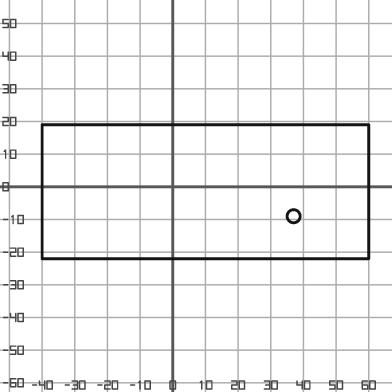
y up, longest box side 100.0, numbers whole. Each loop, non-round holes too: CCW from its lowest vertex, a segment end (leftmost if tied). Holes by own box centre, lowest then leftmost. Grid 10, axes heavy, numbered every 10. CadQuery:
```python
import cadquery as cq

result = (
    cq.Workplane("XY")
    .moveTo(-40.0, -22.0)
    .lineTo(60.0, -22.0)
    .lineTo(60.0, 19.0)
    .lineTo(-40.0, 19.0)
    .close()
    .moveTo(37.0, -9.0)
    .circle(2.0)
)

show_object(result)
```